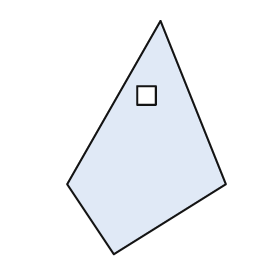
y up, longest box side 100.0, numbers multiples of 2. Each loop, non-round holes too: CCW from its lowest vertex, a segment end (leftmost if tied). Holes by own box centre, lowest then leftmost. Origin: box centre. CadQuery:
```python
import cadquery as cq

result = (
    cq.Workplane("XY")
    .moveTo(-14.0, -50.0)
    .lineTo(34.0, -20.0)
    .lineTo(6.0, 50.0)
    .lineTo(-34.0, -20.0)
    .close()
    .moveTo(-4.0, 14.0)
    .lineTo(4.0, 14.0)
    .lineTo(4.0, 22.0)
    .lineTo(-4.0, 22.0)
    .close()
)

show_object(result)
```